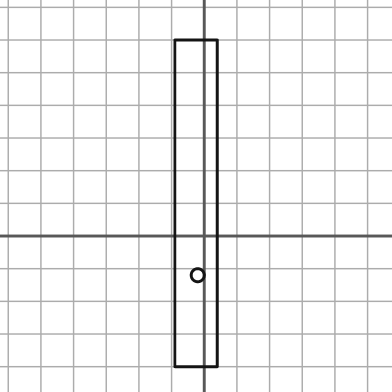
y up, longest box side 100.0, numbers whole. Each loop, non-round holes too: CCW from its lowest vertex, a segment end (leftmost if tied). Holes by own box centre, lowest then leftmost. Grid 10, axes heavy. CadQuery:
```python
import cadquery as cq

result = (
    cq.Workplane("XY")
    .moveTo(-9.0, -40.0)
    .lineTo(4.0, -40.0)
    .lineTo(4.0, 60.0)
    .lineTo(-9.0, 60.0)
    .close()
    .moveTo(-2.0, -12.0)
    .circle(2.0)
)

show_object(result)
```